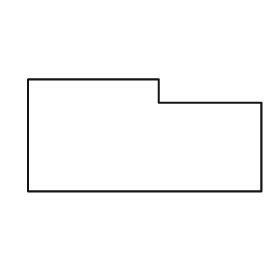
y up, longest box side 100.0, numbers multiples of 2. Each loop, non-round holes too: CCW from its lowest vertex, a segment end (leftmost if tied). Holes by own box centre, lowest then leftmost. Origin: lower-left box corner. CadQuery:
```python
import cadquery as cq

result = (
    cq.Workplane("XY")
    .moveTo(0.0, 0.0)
    .lineTo(100.0, 0.0)
    .lineTo(100.0, 38.0)
    .lineTo(56.0, 38.0)
    .lineTo(56.0, 48.0)
    .lineTo(0.0, 48.0)
    .close()
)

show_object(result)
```